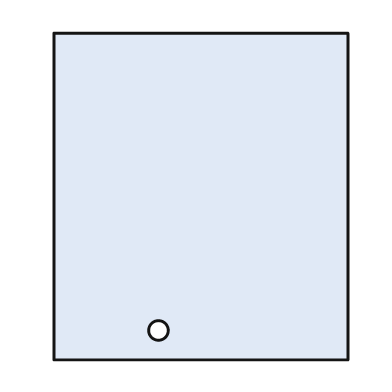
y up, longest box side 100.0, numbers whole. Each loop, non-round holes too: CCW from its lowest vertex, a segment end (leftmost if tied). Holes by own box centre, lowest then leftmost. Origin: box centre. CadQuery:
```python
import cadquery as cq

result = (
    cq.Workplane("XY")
    .moveTo(-45.0, -50.0)
    .lineTo(45.0, -50.0)
    .lineTo(45.0, 50.0)
    .lineTo(-45.0, 50.0)
    .close()
    .moveTo(-13.0, -41.0)
    .circle(3.0)
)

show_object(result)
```